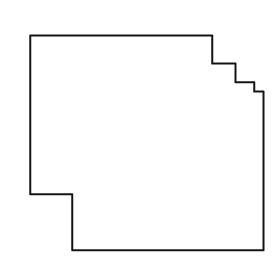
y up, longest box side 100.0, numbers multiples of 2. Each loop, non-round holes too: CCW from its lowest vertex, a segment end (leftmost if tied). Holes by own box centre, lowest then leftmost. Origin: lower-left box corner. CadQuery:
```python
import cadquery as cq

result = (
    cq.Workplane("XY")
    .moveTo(18.0, 0.0)
    .lineTo(100.0, 0.0)
    .lineTo(100.0, 68.0)
    .lineTo(96.0, 68.0)
    .lineTo(96.0, 72.0)
    .lineTo(88.0, 72.0)
    .lineTo(88.0, 80.0)
    .lineTo(78.0, 80.0)
    .lineTo(78.0, 92.0)
    .lineTo(0.0, 92.0)
    .lineTo(0.0, 24.0)
    .lineTo(18.0, 24.0)
    .close()
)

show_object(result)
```